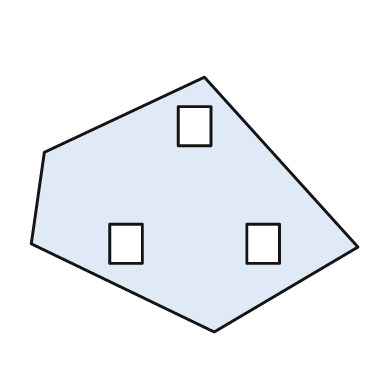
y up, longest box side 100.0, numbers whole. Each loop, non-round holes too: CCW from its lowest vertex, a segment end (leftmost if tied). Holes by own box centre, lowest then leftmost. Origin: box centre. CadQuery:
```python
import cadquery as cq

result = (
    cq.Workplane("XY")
    .moveTo(6.0, -39.0)
    .lineTo(50.0, -13.0)
    .lineTo(3.0, 39.0)
    .lineTo(-46.0, 16.0)
    .lineTo(-50.0, -12.0)
    .close()
    .moveTo(-26.0, -18.0)
    .lineTo(-16.0, -18.0)
    .lineTo(-16.0, -6.0)
    .lineTo(-26.0, -6.0)
    .close()
    .moveTo(16.0, -18.0)
    .lineTo(26.0, -18.0)
    .lineTo(26.0, -6.0)
    .lineTo(16.0, -6.0)
    .close()
    .moveTo(-5.0, 18.0)
    .lineTo(5.0, 18.0)
    .lineTo(5.0, 30.0)
    .lineTo(-5.0, 30.0)
    .close()
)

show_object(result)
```